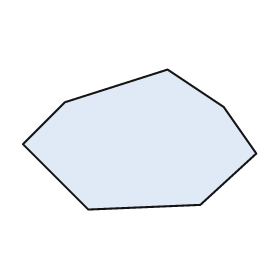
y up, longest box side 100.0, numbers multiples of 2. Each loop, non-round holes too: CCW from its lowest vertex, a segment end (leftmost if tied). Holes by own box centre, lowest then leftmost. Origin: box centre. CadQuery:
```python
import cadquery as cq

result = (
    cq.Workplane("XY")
    .moveTo(-22.0, -30.0)
    .lineTo(26.0, -28.0)
    .lineTo(50.0, -6.0)
    .lineTo(36.0, 14.0)
    .lineTo(12.0, 30.0)
    .lineTo(-32.0, 16.0)
    .lineTo(-50.0, -2.0)
    .close()
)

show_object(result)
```